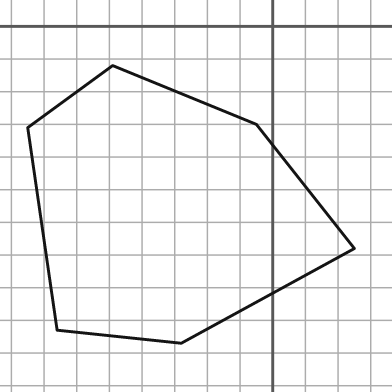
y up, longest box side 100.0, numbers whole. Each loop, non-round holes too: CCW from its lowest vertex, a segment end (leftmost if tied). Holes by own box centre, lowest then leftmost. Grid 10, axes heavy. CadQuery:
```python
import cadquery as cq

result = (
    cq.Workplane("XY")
    .moveTo(-28.0, -97.0)
    .lineTo(25.0, -68.0)
    .lineTo(-5.0, -30.0)
    .lineTo(-49.0, -12.0)
    .lineTo(-75.0, -31.0)
    .lineTo(-66.0, -93.0)
    .close()
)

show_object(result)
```